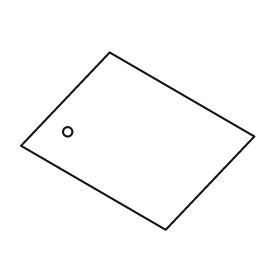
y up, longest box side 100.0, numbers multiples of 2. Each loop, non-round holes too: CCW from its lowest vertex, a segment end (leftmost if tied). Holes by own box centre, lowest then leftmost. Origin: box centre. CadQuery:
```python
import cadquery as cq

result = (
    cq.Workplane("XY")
    .moveTo(12.0, -38.0)
    .lineTo(50.0, 2.0)
    .lineTo(-12.0, 38.0)
    .lineTo(-50.0, -2.0)
    .close()
    .moveTo(-30.0, 4.0)
    .circle(2.0)
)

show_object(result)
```